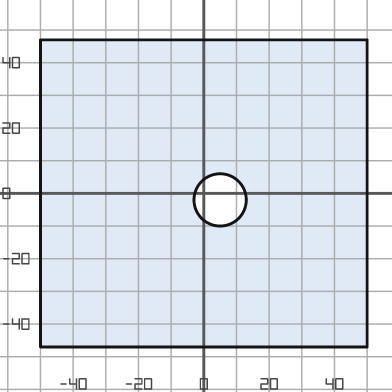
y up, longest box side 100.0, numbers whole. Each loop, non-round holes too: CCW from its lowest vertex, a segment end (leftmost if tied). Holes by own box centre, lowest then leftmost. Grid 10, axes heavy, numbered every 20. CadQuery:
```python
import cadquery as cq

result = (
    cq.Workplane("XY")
    .moveTo(-50.0, -47.0)
    .lineTo(50.0, -47.0)
    .lineTo(50.0, 47.0)
    .lineTo(-50.0, 47.0)
    .close()
    .moveTo(5.0, -2.0)
    .circle(8.0)
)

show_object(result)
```